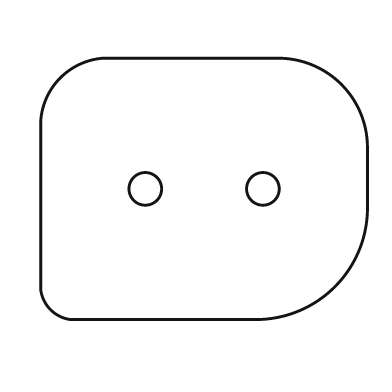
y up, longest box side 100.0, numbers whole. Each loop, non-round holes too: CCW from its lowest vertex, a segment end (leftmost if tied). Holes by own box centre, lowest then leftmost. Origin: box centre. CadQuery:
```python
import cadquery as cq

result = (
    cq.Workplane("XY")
    .moveTo(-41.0, -40.0)
    .lineTo(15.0, -40.0)
    .threePointArc((40.0, -30.0), (50.0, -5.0))
    .lineTo(50.0, 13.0)
    .threePointArc((42.0, 32.0), (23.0, 40.0))
    .lineTo(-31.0, 40.0)
    .threePointArc((-44.0, 34.0), (-50.0, 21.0))
    .lineTo(-50.0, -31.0)
    .threePointArc((-47.0, -37.0), (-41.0, -40.0))
    .close()
    .moveTo(-18.0, 0.0)
    .circle(5.0)
    .moveTo(18.0, 0.0)
    .circle(5.0)
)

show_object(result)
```